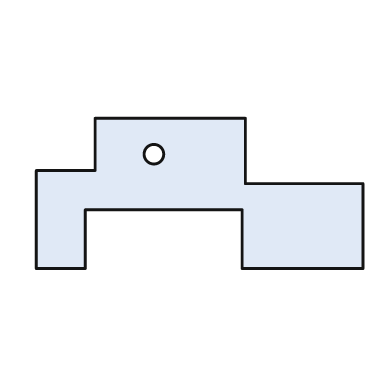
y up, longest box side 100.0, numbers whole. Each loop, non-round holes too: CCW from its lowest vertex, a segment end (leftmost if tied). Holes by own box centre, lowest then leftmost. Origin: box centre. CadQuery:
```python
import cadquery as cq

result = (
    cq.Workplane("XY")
    .moveTo(-50.0, -23.0)
    .lineTo(-35.0, -23.0)
    .lineTo(-35.0, -5.0)
    .lineTo(13.0, -5.0)
    .lineTo(13.0, -23.0)
    .lineTo(50.0, -23.0)
    .lineTo(50.0, 3.0)
    .lineTo(14.0, 3.0)
    .lineTo(14.0, 23.0)
    .lineTo(-32.0, 23.0)
    .lineTo(-32.0, 7.0)
    .lineTo(-50.0, 7.0)
    .close()
    .moveTo(-14.0, 12.0)
    .circle(3.0)
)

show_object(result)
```